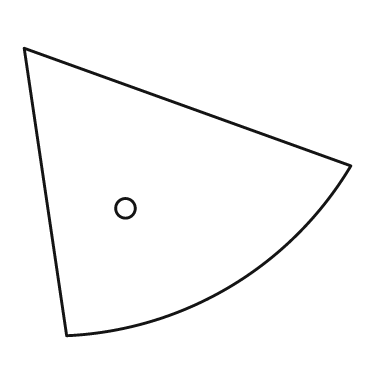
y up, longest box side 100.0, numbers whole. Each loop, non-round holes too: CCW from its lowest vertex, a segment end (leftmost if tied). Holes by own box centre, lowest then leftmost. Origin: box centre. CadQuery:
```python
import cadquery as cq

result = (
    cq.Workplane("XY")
    .moveTo(-37.0, -44.0)
    .threePointArc((13.0, -29.0), (50.0, 8.0))
    .lineTo(-50.0, 44.0)
    .close()
    .moveTo(-19.0, -5.0)
    .circle(3.0)
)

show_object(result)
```